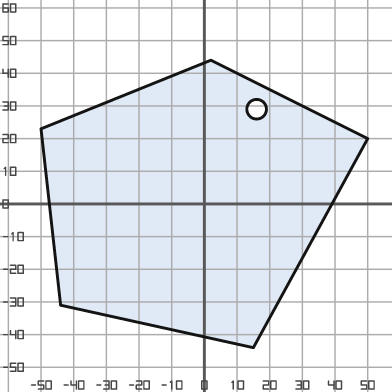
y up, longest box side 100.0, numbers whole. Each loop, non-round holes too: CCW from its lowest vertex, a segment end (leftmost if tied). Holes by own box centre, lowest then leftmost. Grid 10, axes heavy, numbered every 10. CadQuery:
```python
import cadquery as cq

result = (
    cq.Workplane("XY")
    .moveTo(15.0, -44.0)
    .lineTo(50.0, 20.0)
    .lineTo(2.0, 44.0)
    .lineTo(-50.0, 23.0)
    .lineTo(-44.0, -31.0)
    .close()
    .moveTo(16.0, 29.0)
    .circle(3.0)
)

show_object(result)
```